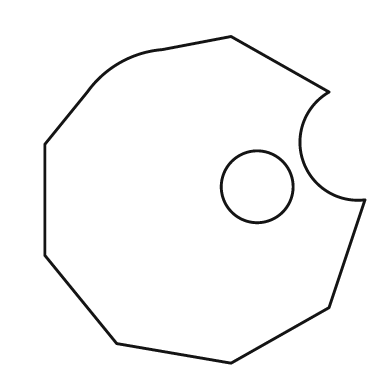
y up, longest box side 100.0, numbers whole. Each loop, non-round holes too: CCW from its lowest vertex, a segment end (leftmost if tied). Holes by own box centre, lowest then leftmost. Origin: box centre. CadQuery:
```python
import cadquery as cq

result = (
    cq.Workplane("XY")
    .moveTo(8.0, -50.0)
    .lineTo(38.0, -33.0)
    .lineTo(49.0, 0.0)
    .threePointArc((30.0, 12.0), (38.0, 33.0))
    .lineTo(8.0, 50.0)
    .lineTo(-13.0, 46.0)
    .threePointArc((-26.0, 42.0), (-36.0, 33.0))
    .lineTo(-49.0, 17.0)
    .lineTo(-49.0, -17.0)
    .lineTo(-27.0, -44.0)
    .close()
    .moveTo(16.0, 4.0)
    .circle(11.0)
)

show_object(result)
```